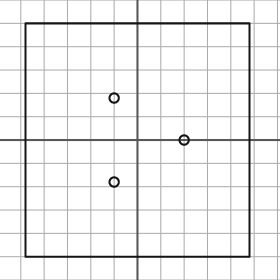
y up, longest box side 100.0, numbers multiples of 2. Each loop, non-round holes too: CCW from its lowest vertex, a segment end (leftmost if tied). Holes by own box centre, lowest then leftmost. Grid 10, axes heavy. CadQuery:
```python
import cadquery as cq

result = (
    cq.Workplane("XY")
    .moveTo(-48.0, -50.0)
    .lineTo(48.0, -50.0)
    .lineTo(48.0, 50.0)
    .lineTo(-48.0, 50.0)
    .close()
    .moveTo(-10.0, -18.0)
    .circle(2.0)
    .moveTo(20.0, 0.0)
    .circle(2.0)
    .moveTo(-10.0, 18.0)
    .circle(2.0)
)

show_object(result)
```